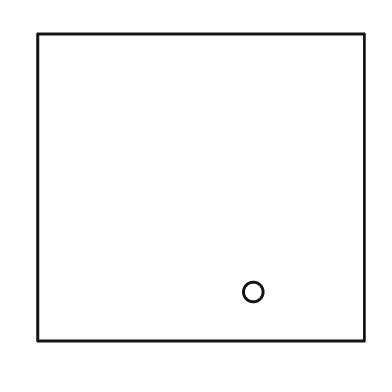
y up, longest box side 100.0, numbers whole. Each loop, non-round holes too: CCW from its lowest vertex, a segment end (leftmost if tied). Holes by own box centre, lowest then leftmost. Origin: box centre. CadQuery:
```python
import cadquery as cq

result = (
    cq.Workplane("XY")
    .moveTo(-50.0, -47.0)
    .lineTo(50.0, -47.0)
    .lineTo(50.0, 47.0)
    .lineTo(-50.0, 47.0)
    .close()
    .moveTo(16.0, -32.0)
    .circle(3.0)
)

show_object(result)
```